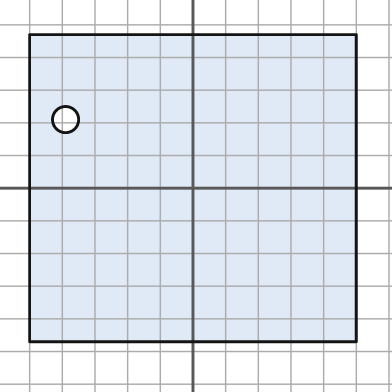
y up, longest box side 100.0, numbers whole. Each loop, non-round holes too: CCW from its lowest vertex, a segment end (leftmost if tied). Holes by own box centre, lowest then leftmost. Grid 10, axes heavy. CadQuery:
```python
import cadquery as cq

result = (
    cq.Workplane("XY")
    .moveTo(-50.0, -47.0)
    .lineTo(50.0, -47.0)
    .lineTo(50.0, 47.0)
    .lineTo(-50.0, 47.0)
    .close()
    .moveTo(-39.0, 21.0)
    .circle(4.0)
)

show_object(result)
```